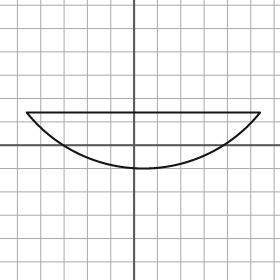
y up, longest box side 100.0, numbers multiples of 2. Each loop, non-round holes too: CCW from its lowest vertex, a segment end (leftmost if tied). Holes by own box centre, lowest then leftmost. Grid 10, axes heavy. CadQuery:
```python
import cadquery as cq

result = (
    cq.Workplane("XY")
    .moveTo(-46.0, 14.0)
    .threePointArc((4.0, -10.0), (54.0, 14.0))
    .close()
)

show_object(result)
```